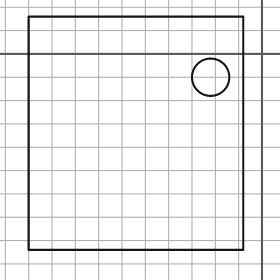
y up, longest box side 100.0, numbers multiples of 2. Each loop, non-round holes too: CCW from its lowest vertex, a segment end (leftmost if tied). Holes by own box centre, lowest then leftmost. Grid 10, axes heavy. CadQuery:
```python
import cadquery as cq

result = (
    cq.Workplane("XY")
    .moveTo(-100.0, -84.0)
    .lineTo(-8.0, -84.0)
    .lineTo(-8.0, 16.0)
    .lineTo(-100.0, 16.0)
    .close()
    .moveTo(-22.0, -10.0)
    .circle(8.0)
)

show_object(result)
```